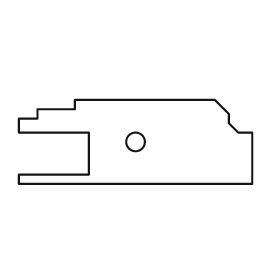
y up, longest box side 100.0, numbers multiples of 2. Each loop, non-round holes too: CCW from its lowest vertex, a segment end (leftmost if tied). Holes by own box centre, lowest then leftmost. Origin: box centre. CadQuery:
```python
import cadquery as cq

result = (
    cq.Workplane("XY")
    .moveTo(-50.0, -18.0)
    .lineTo(50.0, -18.0)
    .lineTo(50.0, 4.0)
    .lineTo(44.0, 4.0)
    .lineTo(40.0, 8.0)
    .lineTo(40.0, 12.0)
    .lineTo(34.0, 18.0)
    .lineTo(-26.0, 18.0)
    .lineTo(-26.0, 14.0)
    .lineTo(-42.0, 14.0)
    .lineTo(-42.0, 10.0)
    .lineTo(-50.0, 10.0)
    .lineTo(-50.0, 4.0)
    .lineTo(-20.0, 4.0)
    .lineTo(-20.0, -14.0)
    .lineTo(-50.0, -14.0)
    .close()
    .moveTo(0.0, 0.0)
    .circle(4.0)
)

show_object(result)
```